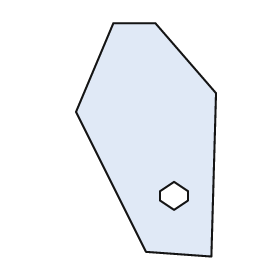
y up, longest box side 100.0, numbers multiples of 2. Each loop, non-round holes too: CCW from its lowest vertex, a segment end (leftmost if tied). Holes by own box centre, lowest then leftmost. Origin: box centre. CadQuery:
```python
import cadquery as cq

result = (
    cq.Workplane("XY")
    .moveTo(28.0, -50.0)
    .lineTo(30.0, 20.0)
    .lineTo(4.0, 50.0)
    .lineTo(-14.0, 50.0)
    .lineTo(-30.0, 12.0)
    .lineTo(0.0, -48.0)
    .close()
    .moveTo(12.0, -30.0)
    .lineTo(18.0, -26.0)
    .lineTo(18.0, -22.0)
    .lineTo(12.0, -18.0)
    .lineTo(6.0, -22.0)
    .lineTo(6.0, -26.0)
    .close()
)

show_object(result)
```